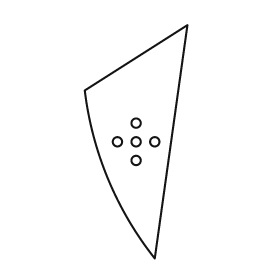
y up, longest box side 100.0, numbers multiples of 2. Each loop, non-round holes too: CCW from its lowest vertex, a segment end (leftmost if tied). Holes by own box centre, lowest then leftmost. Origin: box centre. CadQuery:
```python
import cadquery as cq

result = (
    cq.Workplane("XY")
    .moveTo(8.0, -50.0)
    .lineTo(22.0, 50.0)
    .lineTo(-22.0, 22.0)
    .threePointArc((-12.0, -16.0), (8.0, -50.0))
    .close()
    .moveTo(0.0, -8.0)
    .circle(2.0)
    .moveTo(-8.0, 0.0)
    .circle(2.0)
    .moveTo(0.0, 0.0)
    .circle(2.0)
    .moveTo(8.0, 0.0)
    .circle(2.0)
    .moveTo(0.0, 8.0)
    .circle(2.0)
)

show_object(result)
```